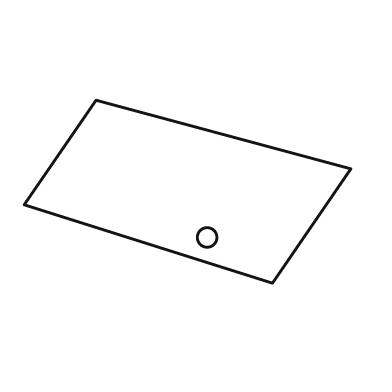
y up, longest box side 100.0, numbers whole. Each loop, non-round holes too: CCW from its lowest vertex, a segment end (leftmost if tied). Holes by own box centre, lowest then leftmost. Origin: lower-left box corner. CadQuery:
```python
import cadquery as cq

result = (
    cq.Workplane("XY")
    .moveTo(76.0, 0.0)
    .lineTo(100.0, 35.0)
    .lineTo(22.0, 56.0)
    .lineTo(0.0, 24.0)
    .close()
    .moveTo(56.0, 14.0)
    .circle(3.0)
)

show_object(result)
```